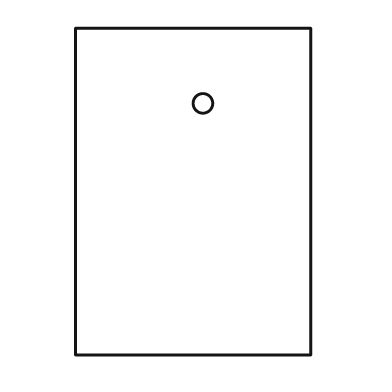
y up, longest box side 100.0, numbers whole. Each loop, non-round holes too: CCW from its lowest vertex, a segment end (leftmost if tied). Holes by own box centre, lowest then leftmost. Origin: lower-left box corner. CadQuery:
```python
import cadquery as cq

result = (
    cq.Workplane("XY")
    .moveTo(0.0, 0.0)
    .lineTo(72.0, 0.0)
    .lineTo(72.0, 100.0)
    .lineTo(0.0, 100.0)
    .close()
    .moveTo(39.0, 77.0)
    .circle(3.0)
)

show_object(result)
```